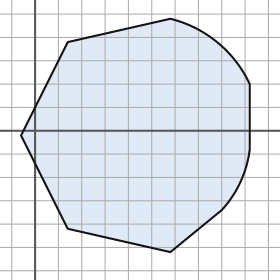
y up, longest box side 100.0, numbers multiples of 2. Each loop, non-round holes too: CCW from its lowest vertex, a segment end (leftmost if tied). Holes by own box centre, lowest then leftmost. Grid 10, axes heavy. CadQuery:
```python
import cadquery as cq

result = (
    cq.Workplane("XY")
    .moveTo(58.0, -52.0)
    .lineTo(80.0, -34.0)
    .threePointArc((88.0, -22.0), (92.0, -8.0))
    .lineTo(92.0, 20.0)
    .threePointArc((78.0, 38.0), (58.0, 48.0))
    .lineTo(14.0, 38.0)
    .lineTo(-6.0, -2.0)
    .lineTo(14.0, -42.0)
    .close()
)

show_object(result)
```